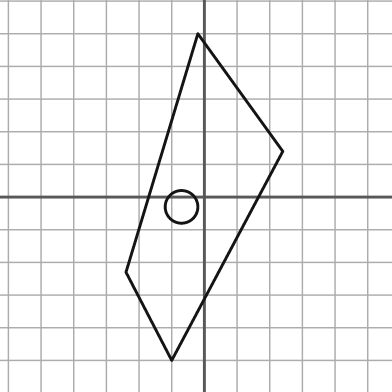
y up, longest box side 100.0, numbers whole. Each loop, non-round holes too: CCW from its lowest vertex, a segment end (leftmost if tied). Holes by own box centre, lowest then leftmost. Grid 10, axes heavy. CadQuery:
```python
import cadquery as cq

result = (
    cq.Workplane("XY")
    .moveTo(-10.0, -50.0)
    .lineTo(24.0, 14.0)
    .lineTo(-2.0, 50.0)
    .lineTo(-24.0, -23.0)
    .close()
    .moveTo(-7.0, -3.0)
    .circle(5.0)
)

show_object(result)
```